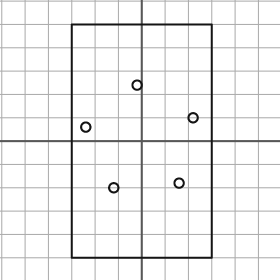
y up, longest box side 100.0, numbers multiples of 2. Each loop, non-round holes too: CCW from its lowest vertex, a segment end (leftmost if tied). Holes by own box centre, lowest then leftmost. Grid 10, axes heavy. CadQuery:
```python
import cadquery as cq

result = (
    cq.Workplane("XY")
    .moveTo(-30.0, -50.0)
    .lineTo(30.0, -50.0)
    .lineTo(30.0, 50.0)
    .lineTo(-30.0, 50.0)
    .close()
    .moveTo(-12.0, -20.0)
    .circle(2.0)
    .moveTo(16.0, -18.0)
    .circle(2.0)
    .moveTo(-24.0, 6.0)
    .circle(2.0)
    .moveTo(22.0, 10.0)
    .circle(2.0)
    .moveTo(-2.0, 24.0)
    .circle(2.0)
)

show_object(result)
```